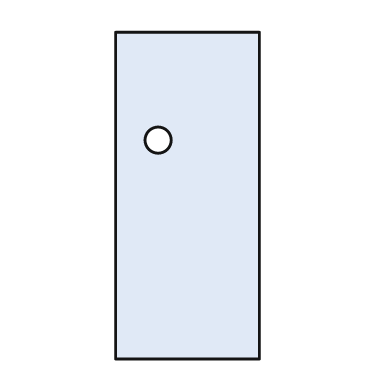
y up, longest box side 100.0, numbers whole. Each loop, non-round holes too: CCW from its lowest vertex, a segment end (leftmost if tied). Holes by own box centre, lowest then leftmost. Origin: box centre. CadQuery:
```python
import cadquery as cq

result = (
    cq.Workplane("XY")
    .moveTo(-22.0, -50.0)
    .lineTo(22.0, -50.0)
    .lineTo(22.0, 50.0)
    .lineTo(-22.0, 50.0)
    .close()
    .moveTo(-9.0, 17.0)
    .circle(4.0)
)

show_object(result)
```